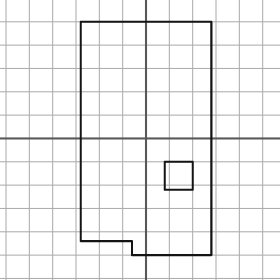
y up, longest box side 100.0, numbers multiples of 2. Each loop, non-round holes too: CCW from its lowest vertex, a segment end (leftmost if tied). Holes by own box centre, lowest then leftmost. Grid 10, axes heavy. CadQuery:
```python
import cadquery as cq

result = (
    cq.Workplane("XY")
    .moveTo(-6.0, -50.0)
    .lineTo(28.0, -50.0)
    .lineTo(28.0, 50.0)
    .lineTo(-28.0, 50.0)
    .lineTo(-28.0, -44.0)
    .lineTo(-6.0, -44.0)
    .close()
    .moveTo(8.0, -22.0)
    .lineTo(20.0, -22.0)
    .lineTo(20.0, -10.0)
    .lineTo(8.0, -10.0)
    .close()
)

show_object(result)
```